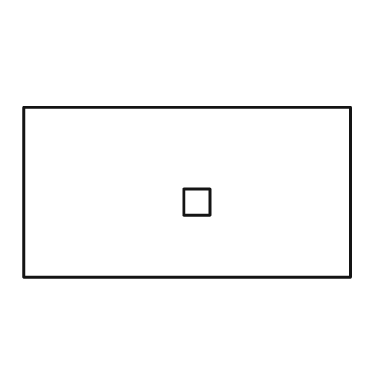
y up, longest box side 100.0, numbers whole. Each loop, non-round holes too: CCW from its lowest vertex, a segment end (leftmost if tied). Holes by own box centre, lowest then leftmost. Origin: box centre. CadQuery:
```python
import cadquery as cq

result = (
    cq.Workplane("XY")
    .moveTo(-50.0, -26.0)
    .lineTo(50.0, -26.0)
    .lineTo(50.0, 26.0)
    .lineTo(-50.0, 26.0)
    .close()
    .moveTo(-1.0, -7.0)
    .lineTo(7.0, -7.0)
    .lineTo(7.0, 1.0)
    .lineTo(-1.0, 1.0)
    .close()
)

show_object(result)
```